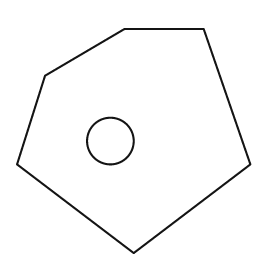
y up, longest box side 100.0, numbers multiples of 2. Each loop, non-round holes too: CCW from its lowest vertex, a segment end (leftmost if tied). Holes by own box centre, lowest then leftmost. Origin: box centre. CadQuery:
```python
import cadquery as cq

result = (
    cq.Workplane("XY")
    .moveTo(0.0, -48.0)
    .lineTo(50.0, -10.0)
    .lineTo(30.0, 48.0)
    .lineTo(-4.0, 48.0)
    .lineTo(-38.0, 28.0)
    .lineTo(-50.0, -10.0)
    .close()
    .moveTo(-10.0, 0.0)
    .circle(10.0)
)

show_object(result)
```